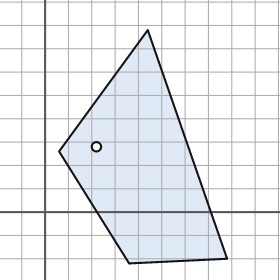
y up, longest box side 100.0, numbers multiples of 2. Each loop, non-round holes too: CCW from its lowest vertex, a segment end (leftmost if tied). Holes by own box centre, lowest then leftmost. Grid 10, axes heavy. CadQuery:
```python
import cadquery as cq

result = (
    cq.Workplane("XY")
    .moveTo(36.0, -22.0)
    .lineTo(78.0, -20.0)
    .lineTo(44.0, 78.0)
    .lineTo(6.0, 26.0)
    .close()
    .moveTo(22.0, 28.0)
    .circle(2.0)
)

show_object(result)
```